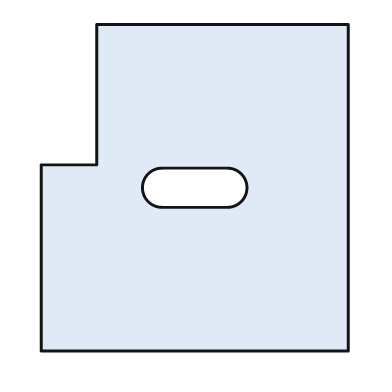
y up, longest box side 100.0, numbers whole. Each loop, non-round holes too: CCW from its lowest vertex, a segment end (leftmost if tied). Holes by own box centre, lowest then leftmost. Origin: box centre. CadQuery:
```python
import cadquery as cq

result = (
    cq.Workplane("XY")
    .moveTo(-47.0, -50.0)
    .lineTo(47.0, -50.0)
    .lineTo(47.0, 50.0)
    .lineTo(-30.0, 50.0)
    .lineTo(-30.0, 7.0)
    .lineTo(-47.0, 7.0)
    .close()
    .moveTo(-10.0, -6.0)
    .lineTo(10.0, -6.0)
    .threePointArc((16.0, 0.0), (10.0, 6.0))
    .lineTo(-10.0, 6.0)
    .threePointArc((-16.0, 0.0), (-10.0, -6.0))
    .close()
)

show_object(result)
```